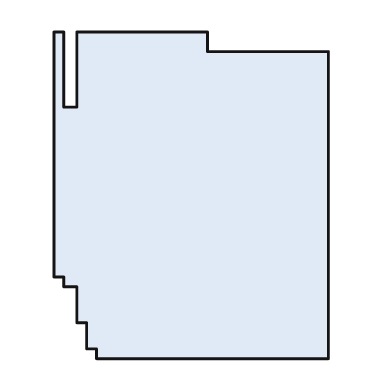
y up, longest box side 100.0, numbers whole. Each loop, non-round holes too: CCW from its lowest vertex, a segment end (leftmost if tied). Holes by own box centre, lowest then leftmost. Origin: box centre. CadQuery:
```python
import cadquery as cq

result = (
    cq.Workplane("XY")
    .moveTo(-29.0, -50.0)
    .lineTo(42.0, -50.0)
    .lineTo(42.0, 44.0)
    .lineTo(5.0, 44.0)
    .lineTo(5.0, 50.0)
    .lineTo(-35.0, 50.0)
    .lineTo(-35.0, 27.0)
    .lineTo(-39.0, 27.0)
    .lineTo(-39.0, 50.0)
    .lineTo(-42.0, 50.0)
    .lineTo(-42.0, -25.0)
    .lineTo(-39.0, -25.0)
    .lineTo(-39.0, -28.0)
    .lineTo(-35.0, -28.0)
    .lineTo(-35.0, -39.0)
    .lineTo(-32.0, -39.0)
    .lineTo(-32.0, -47.0)
    .lineTo(-29.0, -47.0)
    .close()
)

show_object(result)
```